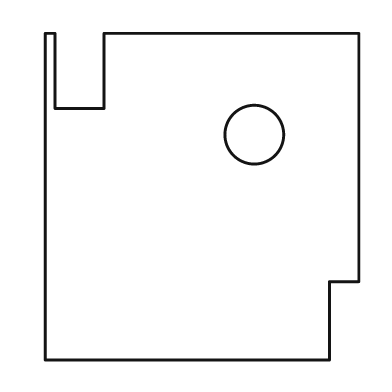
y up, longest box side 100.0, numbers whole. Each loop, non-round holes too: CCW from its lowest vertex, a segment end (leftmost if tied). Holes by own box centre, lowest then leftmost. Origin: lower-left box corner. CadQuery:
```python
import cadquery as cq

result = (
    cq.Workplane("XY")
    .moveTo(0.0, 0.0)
    .lineTo(87.0, 0.0)
    .lineTo(87.0, 24.0)
    .lineTo(96.0, 24.0)
    .lineTo(96.0, 100.0)
    .lineTo(18.0, 100.0)
    .lineTo(18.0, 77.0)
    .lineTo(3.0, 77.0)
    .lineTo(3.0, 100.0)
    .lineTo(0.0, 100.0)
    .close()
    .moveTo(64.0, 69.0)
    .circle(9.0)
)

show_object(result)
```